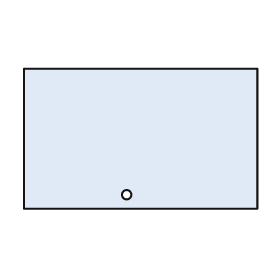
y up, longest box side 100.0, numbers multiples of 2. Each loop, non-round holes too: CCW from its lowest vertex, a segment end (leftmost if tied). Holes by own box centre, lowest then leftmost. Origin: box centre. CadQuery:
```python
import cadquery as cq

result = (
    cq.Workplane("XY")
    .moveTo(-50.0, -30.0)
    .lineTo(50.0, -30.0)
    .lineTo(50.0, 30.0)
    .lineTo(-50.0, 30.0)
    .close()
    .moveTo(-6.0, -24.0)
    .circle(2.0)
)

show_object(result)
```